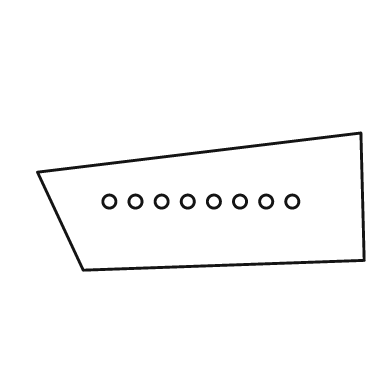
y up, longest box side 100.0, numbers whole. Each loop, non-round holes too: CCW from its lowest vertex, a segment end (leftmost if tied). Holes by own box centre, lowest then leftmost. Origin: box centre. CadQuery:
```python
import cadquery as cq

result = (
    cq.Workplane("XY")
    .moveTo(-36.0, -21.0)
    .lineTo(50.0, -18.0)
    .lineTo(49.0, 21.0)
    .lineTo(-50.0, 9.0)
    .close()
    .moveTo(-28.0, 0.0)
    .circle(2.0)
    .moveTo(-20.0, 0.0)
    .circle(2.0)
    .moveTo(-12.0, 0.0)
    .circle(2.0)
    .moveTo(-4.0, 0.0)
    .circle(2.0)
    .moveTo(4.0, 0.0)
    .circle(2.0)
    .moveTo(12.0, 0.0)
    .circle(2.0)
    .moveTo(20.0, 0.0)
    .circle(2.0)
    .moveTo(28.0, 0.0)
    .circle(2.0)
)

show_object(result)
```